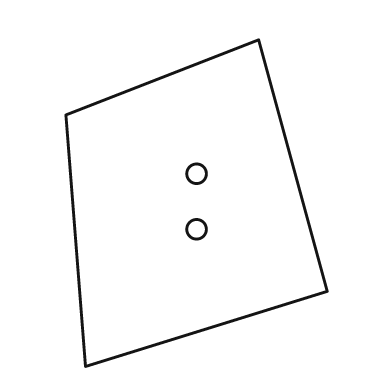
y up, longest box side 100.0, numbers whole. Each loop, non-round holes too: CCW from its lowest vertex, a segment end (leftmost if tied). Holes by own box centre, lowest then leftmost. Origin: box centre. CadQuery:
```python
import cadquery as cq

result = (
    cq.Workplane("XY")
    .moveTo(-34.0, -50.0)
    .lineTo(40.0, -27.0)
    .lineTo(19.0, 50.0)
    .lineTo(-40.0, 27.0)
    .close()
    .moveTo(0.0, -8.0)
    .circle(3.0)
    .moveTo(0.0, 9.0)
    .circle(3.0)
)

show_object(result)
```